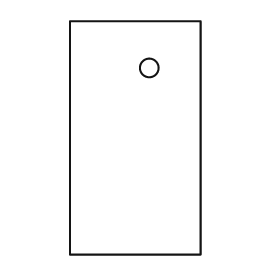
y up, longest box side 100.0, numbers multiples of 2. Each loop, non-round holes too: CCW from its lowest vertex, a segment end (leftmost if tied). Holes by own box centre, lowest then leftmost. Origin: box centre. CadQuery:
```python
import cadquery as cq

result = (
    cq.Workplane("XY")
    .moveTo(-28.0, -50.0)
    .lineTo(28.0, -50.0)
    .lineTo(28.0, 50.0)
    .lineTo(-28.0, 50.0)
    .close()
    .moveTo(6.0, 30.0)
    .circle(4.0)
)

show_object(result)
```